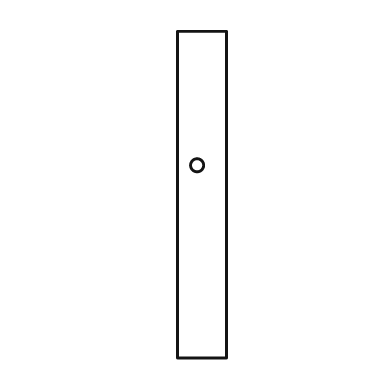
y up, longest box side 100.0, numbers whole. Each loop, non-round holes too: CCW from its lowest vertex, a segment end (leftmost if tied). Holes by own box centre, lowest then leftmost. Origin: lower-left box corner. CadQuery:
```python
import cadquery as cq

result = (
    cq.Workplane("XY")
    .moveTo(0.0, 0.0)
    .lineTo(15.0, 0.0)
    .lineTo(15.0, 100.0)
    .lineTo(0.0, 100.0)
    .close()
    .moveTo(6.0, 59.0)
    .circle(2.0)
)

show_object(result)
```